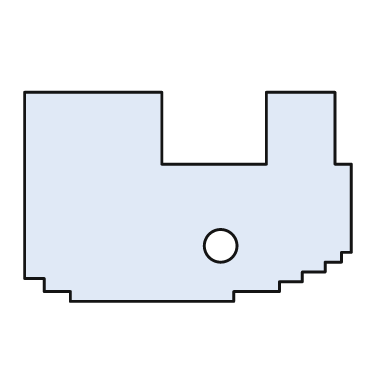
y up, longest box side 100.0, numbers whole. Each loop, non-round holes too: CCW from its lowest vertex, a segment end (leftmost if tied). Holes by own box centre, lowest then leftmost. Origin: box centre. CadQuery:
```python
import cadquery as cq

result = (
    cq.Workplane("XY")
    .moveTo(-36.0, -32.0)
    .lineTo(14.0, -32.0)
    .lineTo(14.0, -29.0)
    .lineTo(28.0, -29.0)
    .lineTo(28.0, -26.0)
    .lineTo(35.0, -26.0)
    .lineTo(35.0, -23.0)
    .lineTo(42.0, -23.0)
    .lineTo(42.0, -20.0)
    .lineTo(47.0, -20.0)
    .lineTo(47.0, -17.0)
    .lineTo(50.0, -17.0)
    .lineTo(50.0, 10.0)
    .lineTo(45.0, 10.0)
    .lineTo(45.0, 32.0)
    .lineTo(24.0, 32.0)
    .lineTo(24.0, 10.0)
    .lineTo(-8.0, 10.0)
    .lineTo(-8.0, 32.0)
    .lineTo(-50.0, 32.0)
    .lineTo(-50.0, -25.0)
    .lineTo(-44.0, -25.0)
    .lineTo(-44.0, -29.0)
    .lineTo(-36.0, -29.0)
    .close()
    .moveTo(10.0, -15.0)
    .circle(5.0)
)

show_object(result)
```